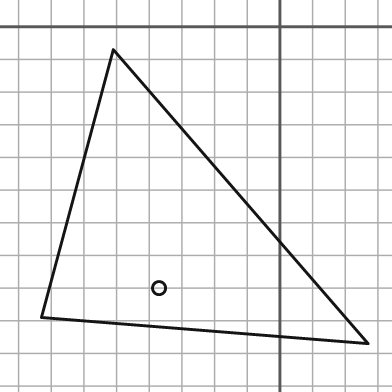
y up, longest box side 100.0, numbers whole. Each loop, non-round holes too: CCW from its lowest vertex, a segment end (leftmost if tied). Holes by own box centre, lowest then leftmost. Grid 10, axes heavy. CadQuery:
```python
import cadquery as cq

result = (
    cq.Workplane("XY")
    .moveTo(27.0, -97.0)
    .lineTo(-51.0, -7.0)
    .lineTo(-73.0, -89.0)
    .close()
    .moveTo(-37.0, -80.0)
    .circle(2.0)
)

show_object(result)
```